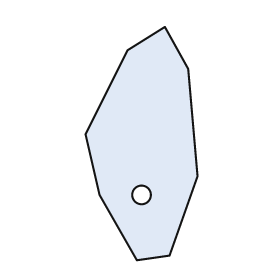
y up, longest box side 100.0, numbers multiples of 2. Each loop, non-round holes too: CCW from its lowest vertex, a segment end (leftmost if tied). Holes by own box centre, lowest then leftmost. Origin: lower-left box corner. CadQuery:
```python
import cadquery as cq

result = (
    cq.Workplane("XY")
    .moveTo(22.0, 0.0)
    .lineTo(36.0, 2.0)
    .lineTo(48.0, 36.0)
    .lineTo(44.0, 82.0)
    .lineTo(34.0, 100.0)
    .lineTo(18.0, 90.0)
    .lineTo(0.0, 54.0)
    .lineTo(6.0, 28.0)
    .close()
    .moveTo(24.0, 28.0)
    .circle(4.0)
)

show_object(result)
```